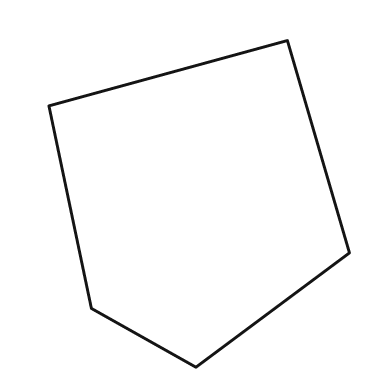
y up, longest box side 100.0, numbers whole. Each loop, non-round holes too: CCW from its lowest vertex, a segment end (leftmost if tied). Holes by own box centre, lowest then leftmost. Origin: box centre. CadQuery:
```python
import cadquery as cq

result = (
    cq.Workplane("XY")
    .moveTo(-1.0, -50.0)
    .lineTo(46.0, -15.0)
    .lineTo(27.0, 50.0)
    .lineTo(-46.0, 30.0)
    .lineTo(-33.0, -32.0)
    .close()
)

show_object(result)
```